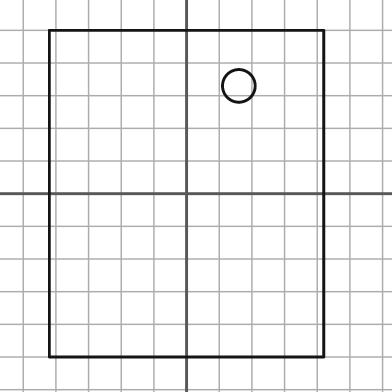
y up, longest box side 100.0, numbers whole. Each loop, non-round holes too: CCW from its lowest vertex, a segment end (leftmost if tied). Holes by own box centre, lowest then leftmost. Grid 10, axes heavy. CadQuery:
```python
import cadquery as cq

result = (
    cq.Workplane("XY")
    .moveTo(-42.0, -50.0)
    .lineTo(42.0, -50.0)
    .lineTo(42.0, 50.0)
    .lineTo(-42.0, 50.0)
    .close()
    .moveTo(16.0, 33.0)
    .circle(5.0)
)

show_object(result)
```